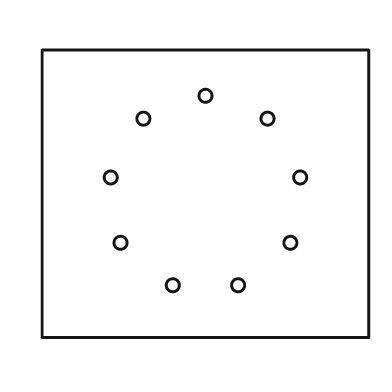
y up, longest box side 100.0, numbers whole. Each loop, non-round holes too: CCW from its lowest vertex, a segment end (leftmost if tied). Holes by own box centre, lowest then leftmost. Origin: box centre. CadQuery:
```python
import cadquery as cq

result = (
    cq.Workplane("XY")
    .moveTo(-50.0, -44.0)
    .lineTo(50.0, -44.0)
    .lineTo(50.0, 44.0)
    .lineTo(-50.0, 44.0)
    .close()
    .moveTo(-10.0, -28.0)
    .circle(2.0)
    .moveTo(10.0, -28.0)
    .circle(2.0)
    .moveTo(-26.0, -15.0)
    .circle(2.0)
    .moveTo(26.0, -15.0)
    .circle(2.0)
    .moveTo(-29.0, 5.0)
    .circle(2.0)
    .moveTo(29.0, 5.0)
    .circle(2.0)
    .moveTo(-19.0, 23.0)
    .circle(2.0)
    .moveTo(19.0, 23.0)
    .circle(2.0)
    .moveTo(0.0, 30.0)
    .circle(2.0)
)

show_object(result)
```